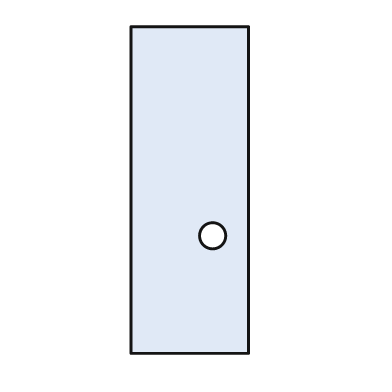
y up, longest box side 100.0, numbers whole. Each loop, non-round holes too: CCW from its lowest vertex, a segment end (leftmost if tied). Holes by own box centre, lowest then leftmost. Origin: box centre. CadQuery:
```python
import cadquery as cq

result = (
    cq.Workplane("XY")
    .moveTo(-18.0, -50.0)
    .lineTo(18.0, -50.0)
    .lineTo(18.0, 50.0)
    .lineTo(-18.0, 50.0)
    .close()
    .moveTo(7.0, -14.0)
    .circle(4.0)
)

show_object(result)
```